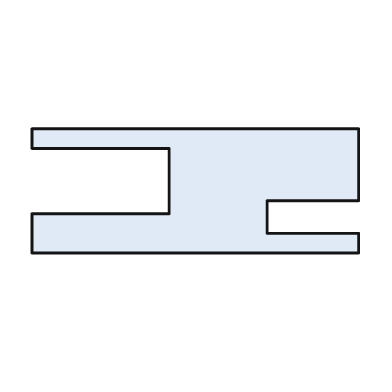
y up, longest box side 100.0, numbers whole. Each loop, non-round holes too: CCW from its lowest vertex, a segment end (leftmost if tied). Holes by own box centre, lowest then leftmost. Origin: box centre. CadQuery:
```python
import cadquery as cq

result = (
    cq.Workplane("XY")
    .moveTo(-50.0, -19.0)
    .lineTo(50.0, -19.0)
    .lineTo(50.0, -13.0)
    .lineTo(22.0, -13.0)
    .lineTo(22.0, -3.0)
    .lineTo(50.0, -3.0)
    .lineTo(50.0, 19.0)
    .lineTo(-50.0, 19.0)
    .lineTo(-50.0, 13.0)
    .lineTo(-8.0, 13.0)
    .lineTo(-8.0, -7.0)
    .lineTo(-50.0, -7.0)
    .close()
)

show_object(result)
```